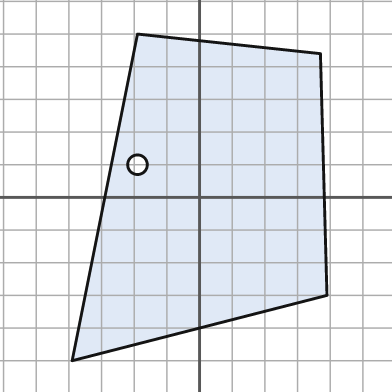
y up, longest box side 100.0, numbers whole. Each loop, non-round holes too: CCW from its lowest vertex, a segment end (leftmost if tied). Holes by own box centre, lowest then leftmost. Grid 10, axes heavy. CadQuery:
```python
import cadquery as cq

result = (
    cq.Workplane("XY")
    .moveTo(-39.0, -50.0)
    .lineTo(39.0, -30.0)
    .lineTo(37.0, 44.0)
    .lineTo(-19.0, 50.0)
    .close()
    .moveTo(-19.0, 10.0)
    .circle(3.0)
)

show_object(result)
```